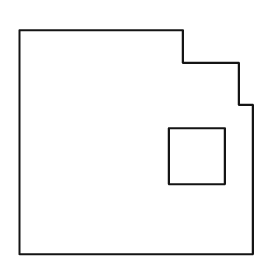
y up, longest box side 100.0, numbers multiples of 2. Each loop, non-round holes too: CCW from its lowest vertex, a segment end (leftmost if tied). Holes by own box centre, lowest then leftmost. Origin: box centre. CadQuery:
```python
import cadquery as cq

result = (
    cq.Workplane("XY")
    .moveTo(-50.0, -48.0)
    .lineTo(50.0, -48.0)
    .lineTo(50.0, 16.0)
    .lineTo(44.0, 16.0)
    .lineTo(44.0, 34.0)
    .lineTo(20.0, 34.0)
    .lineTo(20.0, 48.0)
    .lineTo(-50.0, 48.0)
    .close()
    .moveTo(14.0, -18.0)
    .lineTo(38.0, -18.0)
    .lineTo(38.0, 6.0)
    .lineTo(14.0, 6.0)
    .close()
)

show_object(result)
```